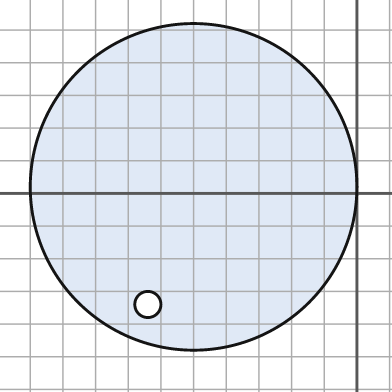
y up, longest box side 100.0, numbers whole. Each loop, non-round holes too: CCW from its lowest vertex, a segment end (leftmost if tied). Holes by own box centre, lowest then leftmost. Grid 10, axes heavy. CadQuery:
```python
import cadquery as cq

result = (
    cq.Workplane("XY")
    .moveTo(-50.0, 2.0)
    .circle(50.0)
    .moveTo(-64.0, -34.0)
    .circle(4.0)
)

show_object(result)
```